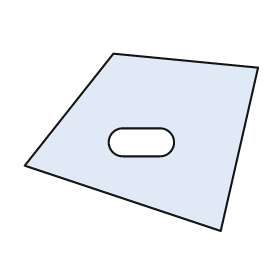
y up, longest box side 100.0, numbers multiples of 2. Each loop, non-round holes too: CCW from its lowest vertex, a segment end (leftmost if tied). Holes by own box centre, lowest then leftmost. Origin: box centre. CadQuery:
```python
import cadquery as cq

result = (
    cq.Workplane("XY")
    .moveTo(34.0, -38.0)
    .lineTo(50.0, 32.0)
    .lineTo(-12.0, 38.0)
    .lineTo(-50.0, -10.0)
    .close()
    .moveTo(-8.0, -6.0)
    .lineTo(8.0, -6.0)
    .threePointArc((14.0, 0.0), (8.0, 6.0))
    .lineTo(-8.0, 6.0)
    .threePointArc((-14.0, 0.0), (-8.0, -6.0))
    .close()
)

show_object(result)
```